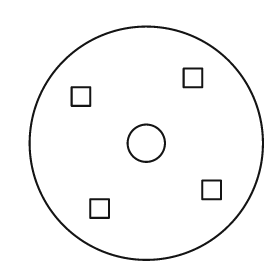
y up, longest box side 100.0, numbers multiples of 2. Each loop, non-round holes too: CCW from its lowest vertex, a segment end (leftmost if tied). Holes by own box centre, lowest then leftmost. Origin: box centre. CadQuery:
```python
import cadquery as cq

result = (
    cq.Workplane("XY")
    .moveTo(0.0, 0.0)
    .circle(50.0)
    .moveTo(-24.0, -32.0)
    .lineTo(-16.0, -32.0)
    .lineTo(-16.0, -24.0)
    .lineTo(-24.0, -24.0)
    .close()
    .moveTo(24.0, -24.0)
    .lineTo(32.0, -24.0)
    .lineTo(32.0, -16.0)
    .lineTo(24.0, -16.0)
    .close()
    .moveTo(0.0, 0.0)
    .circle(8.0)
    .moveTo(-32.0, 16.0)
    .lineTo(-24.0, 16.0)
    .lineTo(-24.0, 24.0)
    .lineTo(-32.0, 24.0)
    .close()
    .moveTo(16.0, 24.0)
    .lineTo(24.0, 24.0)
    .lineTo(24.0, 32.0)
    .lineTo(16.0, 32.0)
    .close()
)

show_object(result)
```